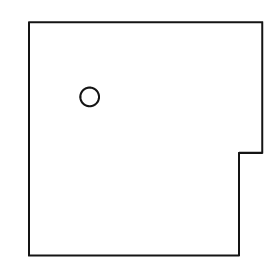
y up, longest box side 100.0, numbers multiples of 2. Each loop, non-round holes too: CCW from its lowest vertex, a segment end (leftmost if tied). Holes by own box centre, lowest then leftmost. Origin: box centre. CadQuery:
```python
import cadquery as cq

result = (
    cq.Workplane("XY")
    .moveTo(-50.0, -50.0)
    .lineTo(40.0, -50.0)
    .lineTo(40.0, -6.0)
    .lineTo(50.0, -6.0)
    .lineTo(50.0, 50.0)
    .lineTo(-50.0, 50.0)
    .close()
    .moveTo(-24.0, 18.0)
    .circle(4.0)
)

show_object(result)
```